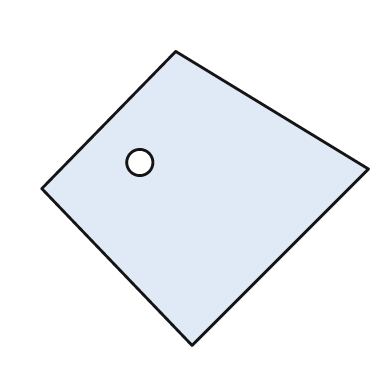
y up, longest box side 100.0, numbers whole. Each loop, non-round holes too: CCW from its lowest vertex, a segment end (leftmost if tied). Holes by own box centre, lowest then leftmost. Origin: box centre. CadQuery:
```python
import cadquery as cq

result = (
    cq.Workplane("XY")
    .moveTo(-4.0, -45.0)
    .lineTo(50.0, 9.0)
    .lineTo(-9.0, 45.0)
    .lineTo(-50.0, 3.0)
    .close()
    .moveTo(-20.0, 11.0)
    .circle(4.0)
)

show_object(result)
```